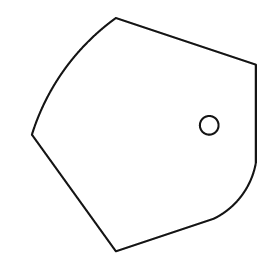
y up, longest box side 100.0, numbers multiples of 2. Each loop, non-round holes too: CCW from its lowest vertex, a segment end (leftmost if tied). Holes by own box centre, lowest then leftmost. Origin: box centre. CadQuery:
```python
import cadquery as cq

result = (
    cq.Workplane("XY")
    .moveTo(-12.0, -50.0)
    .lineTo(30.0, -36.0)
    .threePointArc((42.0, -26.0), (48.0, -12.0))
    .lineTo(48.0, 30.0)
    .lineTo(-12.0, 50.0)
    .threePointArc((-34.0, 28.0), (-48.0, 0.0))
    .close()
    .moveTo(28.0, 4.0)
    .circle(4.0)
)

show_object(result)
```